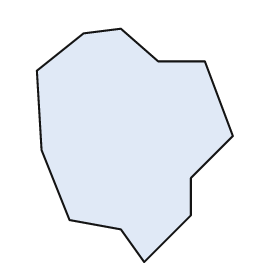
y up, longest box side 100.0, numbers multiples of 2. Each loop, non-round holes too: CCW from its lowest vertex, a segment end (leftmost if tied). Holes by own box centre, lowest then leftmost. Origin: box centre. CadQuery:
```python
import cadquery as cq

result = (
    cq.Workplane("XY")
    .moveTo(4.0, -50.0)
    .lineTo(24.0, -30.0)
    .lineTo(24.0, -14.0)
    .lineTo(42.0, 4.0)
    .lineTo(30.0, 36.0)
    .lineTo(10.0, 36.0)
    .lineTo(-6.0, 50.0)
    .lineTo(-22.0, 48.0)
    .lineTo(-42.0, 32.0)
    .lineTo(-40.0, -2.0)
    .lineTo(-28.0, -32.0)
    .lineTo(-6.0, -36.0)
    .close()
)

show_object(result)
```